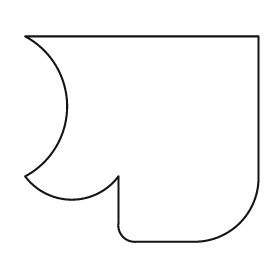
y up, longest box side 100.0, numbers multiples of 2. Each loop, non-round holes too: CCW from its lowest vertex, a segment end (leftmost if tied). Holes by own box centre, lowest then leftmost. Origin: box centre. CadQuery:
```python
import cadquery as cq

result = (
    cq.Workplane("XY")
    .moveTo(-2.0, -44.0)
    .lineTo(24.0, -44.0)
    .threePointArc((42.0, -36.0), (50.0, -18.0))
    .lineTo(50.0, 44.0)
    .lineTo(-50.0, 44.0)
    .threePointArc((-32.0, 14.0), (-50.0, -16.0))
    .threePointArc((-30.0, -26.0), (-10.0, -16.0))
    .lineTo(-10.0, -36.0)
    .threePointArc((-8.0, -42.0), (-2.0, -44.0))
    .close()
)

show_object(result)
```